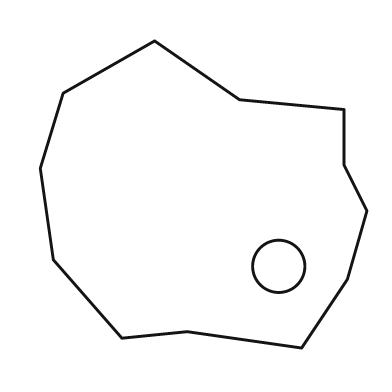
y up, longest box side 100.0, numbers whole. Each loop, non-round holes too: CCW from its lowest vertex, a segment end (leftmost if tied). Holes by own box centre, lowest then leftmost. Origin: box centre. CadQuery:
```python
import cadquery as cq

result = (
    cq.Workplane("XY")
    .moveTo(30.0, -47.0)
    .lineTo(44.0, -26.0)
    .lineTo(50.0, -5.0)
    .lineTo(43.0, 9.0)
    .lineTo(43.0, 26.0)
    .lineTo(11.0, 29.0)
    .lineTo(-15.0, 47.0)
    .lineTo(-43.0, 31.0)
    .lineTo(-50.0, 8.0)
    .lineTo(-46.0, -20.0)
    .lineTo(-25.0, -44.0)
    .lineTo(-5.0, -42.0)
    .close()
    .moveTo(23.0, -22.0)
    .circle(8.0)
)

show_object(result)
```